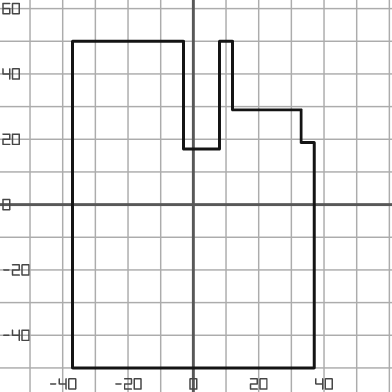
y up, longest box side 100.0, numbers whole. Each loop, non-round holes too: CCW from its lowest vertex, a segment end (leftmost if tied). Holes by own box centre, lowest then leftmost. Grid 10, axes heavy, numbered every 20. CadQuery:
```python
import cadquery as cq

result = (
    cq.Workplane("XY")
    .moveTo(-37.0, -50.0)
    .lineTo(37.0, -50.0)
    .lineTo(37.0, 19.0)
    .lineTo(33.0, 19.0)
    .lineTo(33.0, 29.0)
    .lineTo(12.0, 29.0)
    .lineTo(12.0, 50.0)
    .lineTo(8.0, 50.0)
    .lineTo(8.0, 17.0)
    .lineTo(-3.0, 17.0)
    .lineTo(-3.0, 50.0)
    .lineTo(-37.0, 50.0)
    .close()
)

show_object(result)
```